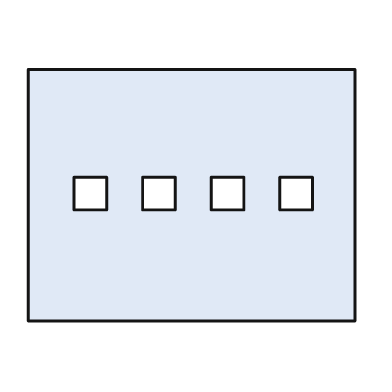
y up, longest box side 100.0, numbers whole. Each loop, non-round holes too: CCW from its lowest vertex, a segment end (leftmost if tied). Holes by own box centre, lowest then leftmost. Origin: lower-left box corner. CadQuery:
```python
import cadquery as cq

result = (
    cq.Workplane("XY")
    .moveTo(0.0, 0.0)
    .lineTo(100.0, 0.0)
    .lineTo(100.0, 77.0)
    .lineTo(0.0, 77.0)
    .close()
    .moveTo(14.0, 34.0)
    .lineTo(24.0, 34.0)
    .lineTo(24.0, 44.0)
    .lineTo(14.0, 44.0)
    .close()
    .moveTo(35.0, 34.0)
    .lineTo(45.0, 34.0)
    .lineTo(45.0, 44.0)
    .lineTo(35.0, 44.0)
    .close()
    .moveTo(56.0, 34.0)
    .lineTo(66.0, 34.0)
    .lineTo(66.0, 44.0)
    .lineTo(56.0, 44.0)
    .close()
    .moveTo(77.0, 34.0)
    .lineTo(87.0, 34.0)
    .lineTo(87.0, 44.0)
    .lineTo(77.0, 44.0)
    .close()
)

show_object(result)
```